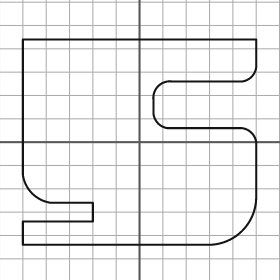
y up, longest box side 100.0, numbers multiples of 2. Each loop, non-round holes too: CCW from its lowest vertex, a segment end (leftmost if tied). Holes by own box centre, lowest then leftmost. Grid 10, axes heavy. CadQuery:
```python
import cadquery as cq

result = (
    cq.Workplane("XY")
    .moveTo(-50.0, -44.0)
    .lineTo(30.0, -44.0)
    .threePointArc((44.0, -38.0), (50.0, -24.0))
    .lineTo(50.0, 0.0)
    .threePointArc((48.0, 4.0), (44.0, 6.0))
    .lineTo(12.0, 6.0)
    .threePointArc((8.0, 8.0), (6.0, 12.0))
    .lineTo(6.0, 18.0)
    .threePointArc((8.0, 24.0), (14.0, 26.0))
    .lineTo(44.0, 26.0)
    .threePointArc((48.0, 28.0), (50.0, 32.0))
    .lineTo(50.0, 44.0)
    .lineTo(-50.0, 44.0)
    .lineTo(-50.0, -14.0)
    .threePointArc((-46.0, -22.0), (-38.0, -26.0))
    .lineTo(-20.0, -26.0)
    .lineTo(-20.0, -34.0)
    .lineTo(-50.0, -34.0)
    .close()
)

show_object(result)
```